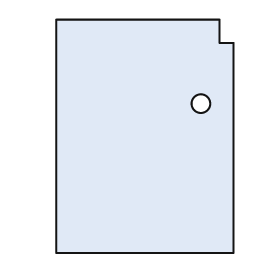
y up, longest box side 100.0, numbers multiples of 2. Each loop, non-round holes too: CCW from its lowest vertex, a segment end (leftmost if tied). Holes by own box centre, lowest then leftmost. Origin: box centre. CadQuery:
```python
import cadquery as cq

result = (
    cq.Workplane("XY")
    .moveTo(-38.0, -50.0)
    .lineTo(38.0, -50.0)
    .lineTo(38.0, 40.0)
    .lineTo(32.0, 40.0)
    .lineTo(32.0, 50.0)
    .lineTo(-38.0, 50.0)
    .close()
    .moveTo(24.0, 14.0)
    .circle(4.0)
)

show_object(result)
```